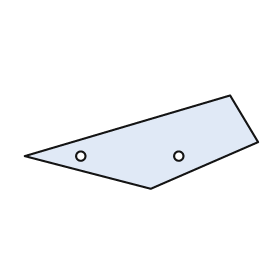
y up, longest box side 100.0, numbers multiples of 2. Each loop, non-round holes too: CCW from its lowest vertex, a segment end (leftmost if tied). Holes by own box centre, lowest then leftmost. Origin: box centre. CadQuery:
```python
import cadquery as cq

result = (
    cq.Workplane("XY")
    .moveTo(4.0, -20.0)
    .lineTo(50.0, 0.0)
    .lineTo(38.0, 20.0)
    .lineTo(-50.0, -6.0)
    .close()
    .moveTo(-26.0, -6.0)
    .circle(2.0)
    .moveTo(16.0, -6.0)
    .circle(2.0)
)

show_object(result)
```